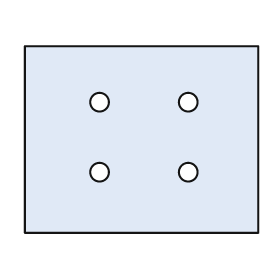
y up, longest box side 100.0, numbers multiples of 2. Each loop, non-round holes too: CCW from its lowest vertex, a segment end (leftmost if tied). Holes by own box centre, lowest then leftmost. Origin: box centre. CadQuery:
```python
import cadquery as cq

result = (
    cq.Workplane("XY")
    .moveTo(-50.0, -40.0)
    .lineTo(50.0, -40.0)
    .lineTo(50.0, 40.0)
    .lineTo(-50.0, 40.0)
    .close()
    .moveTo(-18.0, -14.0)
    .circle(4.0)
    .moveTo(20.0, -14.0)
    .circle(4.0)
    .moveTo(-18.0, 16.0)
    .circle(4.0)
    .moveTo(20.0, 16.0)
    .circle(4.0)
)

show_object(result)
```